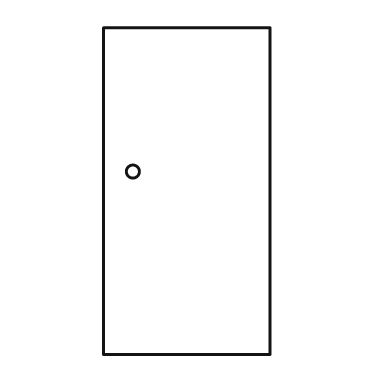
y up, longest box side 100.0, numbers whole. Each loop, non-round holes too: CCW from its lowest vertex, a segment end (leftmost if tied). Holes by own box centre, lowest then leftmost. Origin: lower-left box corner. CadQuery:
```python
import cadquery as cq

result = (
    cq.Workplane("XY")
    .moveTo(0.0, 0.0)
    .lineTo(51.0, 0.0)
    .lineTo(51.0, 100.0)
    .lineTo(0.0, 100.0)
    .close()
    .moveTo(9.0, 56.0)
    .circle(2.0)
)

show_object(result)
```